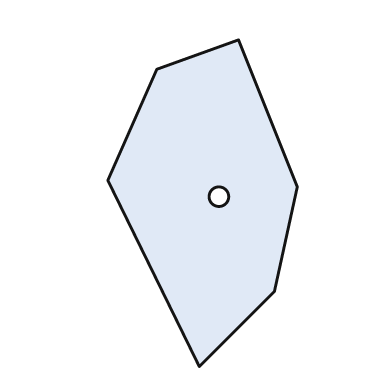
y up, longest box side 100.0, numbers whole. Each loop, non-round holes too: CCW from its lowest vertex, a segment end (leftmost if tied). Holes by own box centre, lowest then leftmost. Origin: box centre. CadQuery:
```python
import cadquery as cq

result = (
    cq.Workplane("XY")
    .moveTo(-1.0, -50.0)
    .lineTo(22.0, -27.0)
    .lineTo(29.0, 5.0)
    .lineTo(11.0, 50.0)
    .lineTo(-14.0, 41.0)
    .lineTo(-29.0, 7.0)
    .close()
    .moveTo(5.0, 2.0)
    .circle(3.0)
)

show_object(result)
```